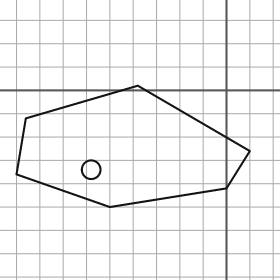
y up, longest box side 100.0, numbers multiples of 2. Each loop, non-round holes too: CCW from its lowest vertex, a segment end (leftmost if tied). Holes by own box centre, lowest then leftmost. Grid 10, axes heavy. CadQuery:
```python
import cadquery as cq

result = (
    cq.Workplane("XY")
    .moveTo(-50.0, -50.0)
    .lineTo(0.0, -42.0)
    .lineTo(10.0, -26.0)
    .lineTo(-38.0, 2.0)
    .lineTo(-86.0, -12.0)
    .lineTo(-90.0, -36.0)
    .close()
    .moveTo(-58.0, -34.0)
    .circle(4.0)
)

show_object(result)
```